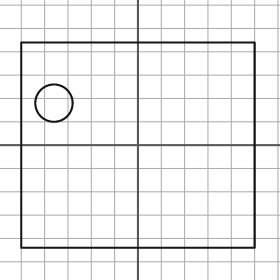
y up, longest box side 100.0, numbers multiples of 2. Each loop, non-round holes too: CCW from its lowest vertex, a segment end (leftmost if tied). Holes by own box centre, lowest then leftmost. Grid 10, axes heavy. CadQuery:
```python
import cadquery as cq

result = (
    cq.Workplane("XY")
    .moveTo(-50.0, -44.0)
    .lineTo(50.0, -44.0)
    .lineTo(50.0, 44.0)
    .lineTo(-50.0, 44.0)
    .close()
    .moveTo(-36.0, 18.0)
    .circle(8.0)
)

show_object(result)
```